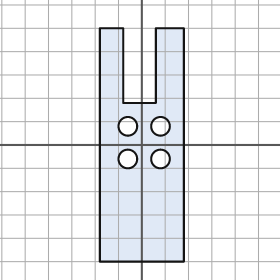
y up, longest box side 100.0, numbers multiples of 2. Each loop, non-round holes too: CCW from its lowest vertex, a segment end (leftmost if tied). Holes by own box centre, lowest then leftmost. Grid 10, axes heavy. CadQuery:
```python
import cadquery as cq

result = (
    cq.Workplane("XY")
    .moveTo(-18.0, -50.0)
    .lineTo(18.0, -50.0)
    .lineTo(18.0, 50.0)
    .lineTo(6.0, 50.0)
    .lineTo(6.0, 18.0)
    .lineTo(-8.0, 18.0)
    .lineTo(-8.0, 50.0)
    .lineTo(-18.0, 50.0)
    .close()
    .moveTo(-6.0, -6.0)
    .circle(4.0)
    .moveTo(8.0, -6.0)
    .circle(4.0)
    .moveTo(-6.0, 8.0)
    .circle(4.0)
    .moveTo(8.0, 8.0)
    .circle(4.0)
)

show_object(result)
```